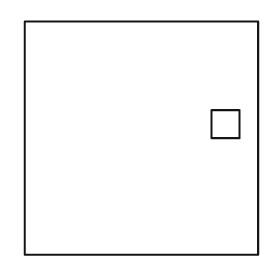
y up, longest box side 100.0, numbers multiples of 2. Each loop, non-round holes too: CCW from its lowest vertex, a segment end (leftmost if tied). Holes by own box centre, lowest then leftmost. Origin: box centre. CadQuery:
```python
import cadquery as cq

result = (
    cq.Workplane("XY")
    .moveTo(-50.0, -50.0)
    .lineTo(50.0, -50.0)
    .lineTo(50.0, 50.0)
    .lineTo(-50.0, 50.0)
    .close()
    .moveTo(30.0, 0.0)
    .lineTo(42.0, 0.0)
    .lineTo(42.0, 12.0)
    .lineTo(30.0, 12.0)
    .close()
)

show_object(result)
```